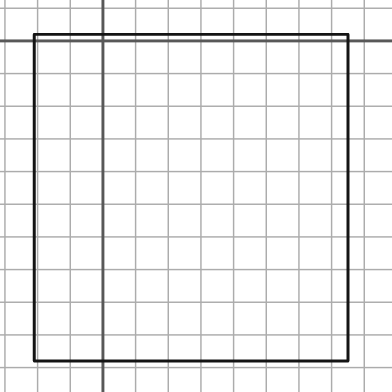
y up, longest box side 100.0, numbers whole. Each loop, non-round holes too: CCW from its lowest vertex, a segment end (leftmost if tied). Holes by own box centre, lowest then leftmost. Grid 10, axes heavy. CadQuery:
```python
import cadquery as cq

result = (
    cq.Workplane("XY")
    .moveTo(-21.0, -98.0)
    .lineTo(75.0, -98.0)
    .lineTo(75.0, 2.0)
    .lineTo(-21.0, 2.0)
    .close()
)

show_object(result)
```